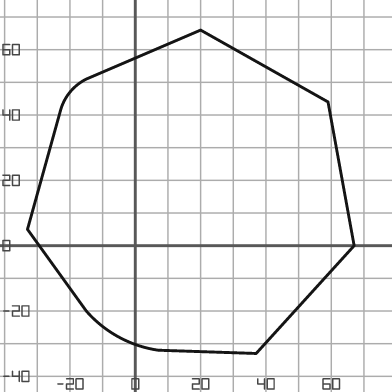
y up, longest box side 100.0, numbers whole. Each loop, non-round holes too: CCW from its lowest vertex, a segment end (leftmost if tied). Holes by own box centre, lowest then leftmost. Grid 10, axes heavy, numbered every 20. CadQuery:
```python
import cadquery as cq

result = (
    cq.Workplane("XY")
    .moveTo(37.0, -33.0)
    .lineTo(67.0, 0.0)
    .lineTo(59.0, 44.0)
    .lineTo(20.0, 66.0)
    .lineTo(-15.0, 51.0)
    .threePointArc((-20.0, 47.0), (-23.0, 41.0))
    .lineTo(-33.0, 5.0)
    .lineTo(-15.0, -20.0)
    .threePointArc((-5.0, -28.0), (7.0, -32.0))
    .close()
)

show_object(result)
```